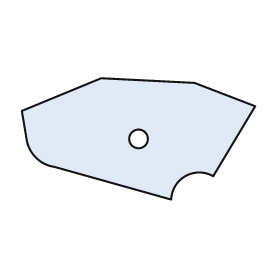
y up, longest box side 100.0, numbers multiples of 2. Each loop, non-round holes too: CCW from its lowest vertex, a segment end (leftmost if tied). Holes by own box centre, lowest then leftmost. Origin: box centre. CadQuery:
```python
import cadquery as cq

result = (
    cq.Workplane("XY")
    .moveTo(14.0, -26.0)
    .threePointArc((20.0, -16.0), (32.0, -16.0))
    .lineTo(50.0, 14.0)
    .lineTo(24.0, 24.0)
    .lineTo(-16.0, 26.0)
    .lineTo(-50.0, 12.0)
    .lineTo(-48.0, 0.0)
    .threePointArc((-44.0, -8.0), (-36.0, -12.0))
    .close()
    .moveTo(0.0, 0.0)
    .circle(4.0)
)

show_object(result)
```